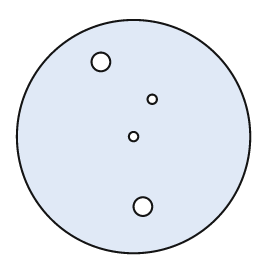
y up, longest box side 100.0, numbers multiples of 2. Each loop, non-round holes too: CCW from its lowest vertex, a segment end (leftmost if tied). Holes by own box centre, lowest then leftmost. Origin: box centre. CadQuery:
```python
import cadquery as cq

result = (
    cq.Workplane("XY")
    .moveTo(0.0, 0.0)
    .circle(50.0)
    .moveTo(4.0, -30.0)
    .circle(4.0)
    .moveTo(0.0, 0.0)
    .circle(2.0)
    .moveTo(8.0, 16.0)
    .circle(2.0)
    .moveTo(-14.0, 32.0)
    .circle(4.0)
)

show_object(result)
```